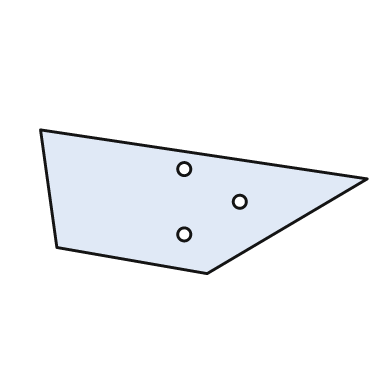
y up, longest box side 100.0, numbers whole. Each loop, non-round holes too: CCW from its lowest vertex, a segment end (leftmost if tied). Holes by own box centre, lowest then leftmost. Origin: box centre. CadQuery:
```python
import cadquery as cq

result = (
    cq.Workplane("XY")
    .moveTo(1.0, -22.0)
    .lineTo(50.0, 7.0)
    .lineTo(-50.0, 22.0)
    .lineTo(-45.0, -14.0)
    .close()
    .moveTo(-6.0, -10.0)
    .circle(2.0)
    .moveTo(11.0, 0.0)
    .circle(2.0)
    .moveTo(-6.0, 10.0)
    .circle(2.0)
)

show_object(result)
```